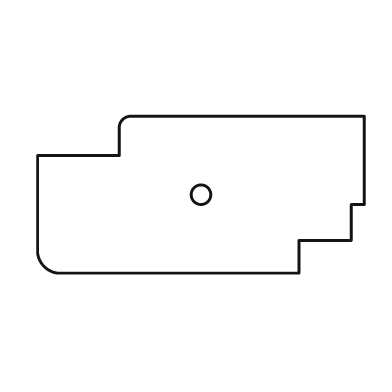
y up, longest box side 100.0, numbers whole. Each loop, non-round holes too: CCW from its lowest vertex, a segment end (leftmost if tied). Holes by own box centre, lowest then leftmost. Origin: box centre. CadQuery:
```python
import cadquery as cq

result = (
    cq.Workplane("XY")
    .moveTo(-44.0, -24.0)
    .lineTo(30.0, -24.0)
    .lineTo(30.0, -14.0)
    .lineTo(46.0, -14.0)
    .lineTo(46.0, -3.0)
    .lineTo(50.0, -3.0)
    .lineTo(50.0, 24.0)
    .lineTo(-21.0, 24.0)
    .threePointArc((-24.0, 23.0), (-25.0, 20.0))
    .lineTo(-25.0, 12.0)
    .lineTo(-50.0, 12.0)
    .lineTo(-50.0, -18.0)
    .threePointArc((-48.0, -22.0), (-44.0, -24.0))
    .close()
    .moveTo(0.0, 0.0)
    .circle(3.0)
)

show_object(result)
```